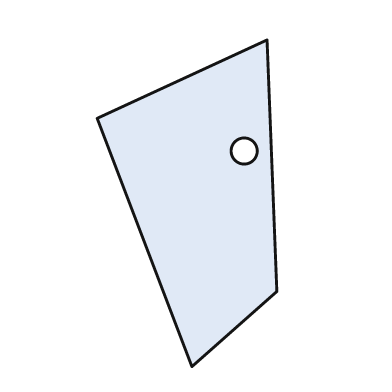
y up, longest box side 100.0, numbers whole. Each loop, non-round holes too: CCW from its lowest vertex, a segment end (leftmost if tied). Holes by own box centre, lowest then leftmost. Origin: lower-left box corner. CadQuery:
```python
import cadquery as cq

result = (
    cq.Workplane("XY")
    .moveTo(29.0, 0.0)
    .lineTo(55.0, 23.0)
    .lineTo(52.0, 100.0)
    .lineTo(0.0, 76.0)
    .close()
    .moveTo(45.0, 66.0)
    .circle(4.0)
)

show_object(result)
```